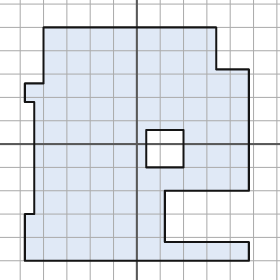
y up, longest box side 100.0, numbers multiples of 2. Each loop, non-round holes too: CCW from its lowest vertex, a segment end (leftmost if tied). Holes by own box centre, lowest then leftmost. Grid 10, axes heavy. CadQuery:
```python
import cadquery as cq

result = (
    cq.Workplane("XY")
    .moveTo(-48.0, -50.0)
    .lineTo(48.0, -50.0)
    .lineTo(48.0, -42.0)
    .lineTo(12.0, -42.0)
    .lineTo(12.0, -20.0)
    .lineTo(48.0, -20.0)
    .lineTo(48.0, 32.0)
    .lineTo(34.0, 32.0)
    .lineTo(34.0, 50.0)
    .lineTo(-40.0, 50.0)
    .lineTo(-40.0, 26.0)
    .lineTo(-48.0, 26.0)
    .lineTo(-48.0, 18.0)
    .lineTo(-44.0, 18.0)
    .lineTo(-44.0, -30.0)
    .lineTo(-48.0, -30.0)
    .close()
    .moveTo(4.0, -10.0)
    .lineTo(20.0, -10.0)
    .lineTo(20.0, 6.0)
    .lineTo(4.0, 6.0)
    .close()
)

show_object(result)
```